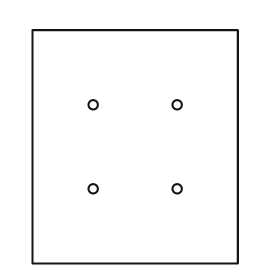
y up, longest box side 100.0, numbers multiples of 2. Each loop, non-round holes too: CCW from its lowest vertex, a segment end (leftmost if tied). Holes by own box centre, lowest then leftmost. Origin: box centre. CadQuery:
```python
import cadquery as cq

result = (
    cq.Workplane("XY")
    .moveTo(-44.0, -50.0)
    .lineTo(44.0, -50.0)
    .lineTo(44.0, 50.0)
    .lineTo(-44.0, 50.0)
    .close()
    .moveTo(-18.0, -18.0)
    .circle(2.0)
    .moveTo(18.0, -18.0)
    .circle(2.0)
    .moveTo(-18.0, 18.0)
    .circle(2.0)
    .moveTo(18.0, 18.0)
    .circle(2.0)
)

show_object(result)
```